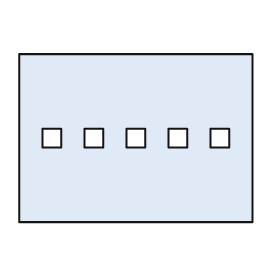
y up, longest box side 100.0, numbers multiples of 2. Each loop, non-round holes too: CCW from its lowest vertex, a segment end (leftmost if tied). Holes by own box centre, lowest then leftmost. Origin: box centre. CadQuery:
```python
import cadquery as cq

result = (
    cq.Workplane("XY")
    .moveTo(-50.0, -36.0)
    .lineTo(50.0, -36.0)
    .lineTo(50.0, 36.0)
    .lineTo(-50.0, 36.0)
    .close()
    .moveTo(-40.0, -4.0)
    .lineTo(-32.0, -4.0)
    .lineTo(-32.0, 4.0)
    .lineTo(-40.0, 4.0)
    .close()
    .moveTo(-22.0, -4.0)
    .lineTo(-14.0, -4.0)
    .lineTo(-14.0, 4.0)
    .lineTo(-22.0, 4.0)
    .close()
    .moveTo(-4.0, -4.0)
    .lineTo(4.0, -4.0)
    .lineTo(4.0, 4.0)
    .lineTo(-4.0, 4.0)
    .close()
    .moveTo(14.0, -4.0)
    .lineTo(22.0, -4.0)
    .lineTo(22.0, 4.0)
    .lineTo(14.0, 4.0)
    .close()
    .moveTo(32.0, -4.0)
    .lineTo(40.0, -4.0)
    .lineTo(40.0, 4.0)
    .lineTo(32.0, 4.0)
    .close()
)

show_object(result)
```